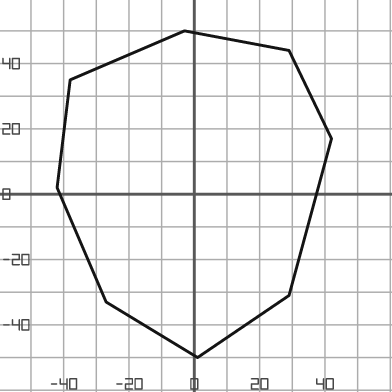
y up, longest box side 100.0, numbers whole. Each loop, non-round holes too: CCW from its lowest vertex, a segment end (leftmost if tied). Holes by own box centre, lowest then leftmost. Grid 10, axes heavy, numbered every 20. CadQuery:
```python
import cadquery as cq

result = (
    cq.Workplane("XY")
    .moveTo(1.0, -50.0)
    .lineTo(29.0, -31.0)
    .lineTo(42.0, 17.0)
    .lineTo(29.0, 44.0)
    .lineTo(-3.0, 50.0)
    .lineTo(-38.0, 35.0)
    .lineTo(-42.0, 2.0)
    .lineTo(-27.0, -33.0)
    .close()
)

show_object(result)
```